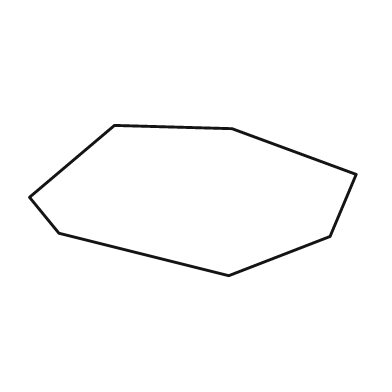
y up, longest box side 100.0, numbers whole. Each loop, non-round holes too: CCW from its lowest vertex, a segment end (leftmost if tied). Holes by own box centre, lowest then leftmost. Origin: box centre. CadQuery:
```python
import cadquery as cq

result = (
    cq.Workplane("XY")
    .moveTo(11.0, -23.0)
    .lineTo(42.0, -11.0)
    .lineTo(50.0, 8.0)
    .lineTo(12.0, 22.0)
    .lineTo(-24.0, 23.0)
    .lineTo(-50.0, 1.0)
    .lineTo(-41.0, -10.0)
    .close()
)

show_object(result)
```